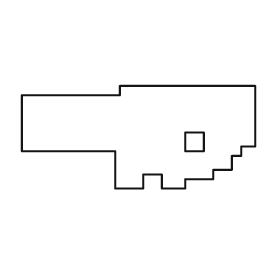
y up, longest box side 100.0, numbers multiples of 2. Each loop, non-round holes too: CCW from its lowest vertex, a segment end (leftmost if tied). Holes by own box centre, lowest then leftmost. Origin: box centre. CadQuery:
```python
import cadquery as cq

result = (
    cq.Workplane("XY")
    .moveTo(-10.0, -22.0)
    .lineTo(2.0, -22.0)
    .lineTo(2.0, -16.0)
    .lineTo(10.0, -16.0)
    .lineTo(10.0, -22.0)
    .lineTo(20.0, -22.0)
    .lineTo(20.0, -18.0)
    .lineTo(32.0, -18.0)
    .lineTo(32.0, -14.0)
    .lineTo(40.0, -14.0)
    .lineTo(40.0, -8.0)
    .lineTo(44.0, -8.0)
    .lineTo(44.0, -4.0)
    .lineTo(50.0, -4.0)
    .lineTo(50.0, 22.0)
    .lineTo(-8.0, 22.0)
    .lineTo(-8.0, 18.0)
    .lineTo(-50.0, 18.0)
    .lineTo(-50.0, -6.0)
    .lineTo(-10.0, -6.0)
    .close()
    .moveTo(20.0, -6.0)
    .lineTo(28.0, -6.0)
    .lineTo(28.0, 2.0)
    .lineTo(20.0, 2.0)
    .close()
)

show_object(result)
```